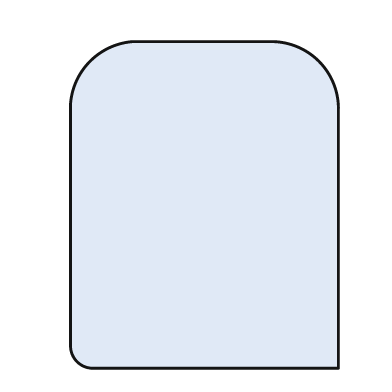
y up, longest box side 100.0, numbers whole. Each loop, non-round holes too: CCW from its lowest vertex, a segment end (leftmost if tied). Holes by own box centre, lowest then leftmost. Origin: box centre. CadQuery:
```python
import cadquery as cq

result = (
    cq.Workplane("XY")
    .moveTo(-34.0, -50.0)
    .lineTo(41.0, -50.0)
    .lineTo(41.0, 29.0)
    .threePointArc((35.0, 44.0), (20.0, 50.0))
    .lineTo(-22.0, 50.0)
    .threePointArc((-35.0, 44.0), (-41.0, 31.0))
    .lineTo(-41.0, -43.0)
    .threePointArc((-39.0, -48.0), (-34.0, -50.0))
    .close()
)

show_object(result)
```